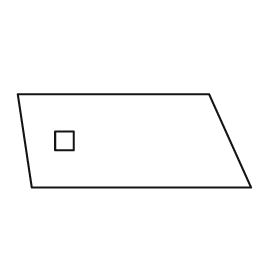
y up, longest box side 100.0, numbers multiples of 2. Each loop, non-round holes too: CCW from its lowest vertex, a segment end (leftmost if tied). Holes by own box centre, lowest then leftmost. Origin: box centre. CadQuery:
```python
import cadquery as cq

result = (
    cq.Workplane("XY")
    .moveTo(-44.0, -20.0)
    .lineTo(50.0, -20.0)
    .lineTo(32.0, 20.0)
    .lineTo(-50.0, 20.0)
    .close()
    .moveTo(-34.0, -4.0)
    .lineTo(-26.0, -4.0)
    .lineTo(-26.0, 4.0)
    .lineTo(-34.0, 4.0)
    .close()
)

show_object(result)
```